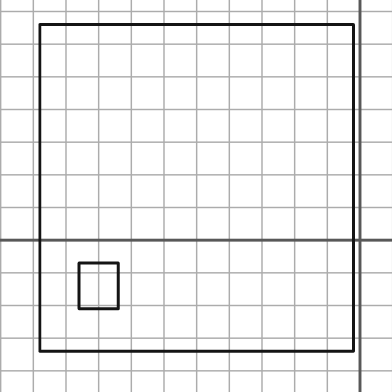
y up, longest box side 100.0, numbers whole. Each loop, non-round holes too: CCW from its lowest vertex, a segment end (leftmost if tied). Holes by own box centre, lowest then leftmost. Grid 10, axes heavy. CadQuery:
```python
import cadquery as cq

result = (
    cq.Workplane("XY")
    .moveTo(-98.0, -34.0)
    .lineTo(-2.0, -34.0)
    .lineTo(-2.0, 66.0)
    .lineTo(-98.0, 66.0)
    .close()
    .moveTo(-86.0, -21.0)
    .lineTo(-74.0, -21.0)
    .lineTo(-74.0, -7.0)
    .lineTo(-86.0, -7.0)
    .close()
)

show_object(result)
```